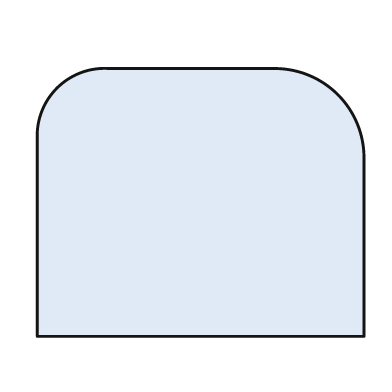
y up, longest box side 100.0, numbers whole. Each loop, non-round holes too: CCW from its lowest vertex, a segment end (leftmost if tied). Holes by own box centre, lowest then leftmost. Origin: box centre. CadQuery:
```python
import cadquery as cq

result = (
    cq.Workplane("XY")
    .moveTo(-50.0, -41.0)
    .lineTo(50.0, -41.0)
    .lineTo(50.0, 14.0)
    .threePointArc((42.0, 33.0), (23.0, 41.0))
    .lineTo(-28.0, 41.0)
    .threePointArc((-44.0, 35.0), (-50.0, 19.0))
    .close()
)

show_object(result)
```